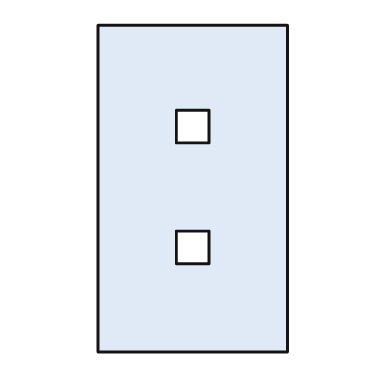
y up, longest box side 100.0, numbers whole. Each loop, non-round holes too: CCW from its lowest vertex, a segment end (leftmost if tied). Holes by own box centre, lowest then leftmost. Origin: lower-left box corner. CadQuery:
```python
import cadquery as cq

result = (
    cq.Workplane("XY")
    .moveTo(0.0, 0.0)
    .lineTo(58.0, 0.0)
    .lineTo(58.0, 100.0)
    .lineTo(0.0, 100.0)
    .close()
    .moveTo(24.0, 27.0)
    .lineTo(34.0, 27.0)
    .lineTo(34.0, 37.0)
    .lineTo(24.0, 37.0)
    .close()
    .moveTo(24.0, 64.0)
    .lineTo(34.0, 64.0)
    .lineTo(34.0, 74.0)
    .lineTo(24.0, 74.0)
    .close()
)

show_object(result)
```